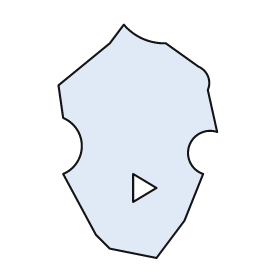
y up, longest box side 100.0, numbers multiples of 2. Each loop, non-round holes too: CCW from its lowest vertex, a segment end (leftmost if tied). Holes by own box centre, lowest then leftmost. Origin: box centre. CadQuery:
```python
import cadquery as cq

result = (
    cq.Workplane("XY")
    .moveTo(8.0, -50.0)
    .lineTo(20.0, -34.0)
    .lineTo(28.0, -14.0)
    .threePointArc((22.0, -2.0), (34.0, 4.0))
    .lineTo(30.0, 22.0)
    .threePointArc((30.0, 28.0), (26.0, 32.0))
    .lineTo(12.0, 42.0)
    .threePointArc((2.0, 44.0), (-6.0, 50.0))
    .lineTo(-12.0, 42.0)
    .lineTo(-34.0, 24.0)
    .lineTo(-32.0, 10.0)
    .threePointArc((-24.0, -2.0), (-32.0, -14.0))
    .lineTo(-18.0, -40.0)
    .lineTo(-12.0, -46.0)
    .close()
    .moveTo(-2.0, -26.0)
    .lineTo(8.0, -20.0)
    .lineTo(-2.0, -14.0)
    .close()
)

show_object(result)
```